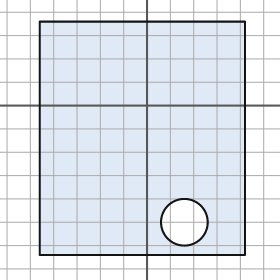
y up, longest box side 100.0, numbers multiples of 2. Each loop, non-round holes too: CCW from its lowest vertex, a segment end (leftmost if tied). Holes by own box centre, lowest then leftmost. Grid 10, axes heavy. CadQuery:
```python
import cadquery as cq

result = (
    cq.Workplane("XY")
    .moveTo(-46.0, -64.0)
    .lineTo(42.0, -64.0)
    .lineTo(42.0, 36.0)
    .lineTo(-46.0, 36.0)
    .close()
    .moveTo(16.0, -50.0)
    .circle(10.0)
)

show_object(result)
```